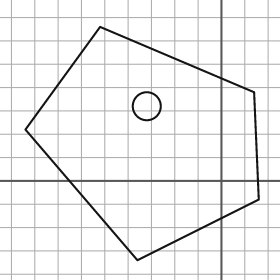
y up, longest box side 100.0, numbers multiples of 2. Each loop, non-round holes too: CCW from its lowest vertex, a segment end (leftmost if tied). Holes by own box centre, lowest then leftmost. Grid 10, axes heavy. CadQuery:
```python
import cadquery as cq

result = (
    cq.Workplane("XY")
    .moveTo(-36.0, -34.0)
    .lineTo(16.0, -8.0)
    .lineTo(14.0, 38.0)
    .lineTo(-52.0, 66.0)
    .lineTo(-84.0, 22.0)
    .close()
    .moveTo(-32.0, 32.0)
    .circle(6.0)
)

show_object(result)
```